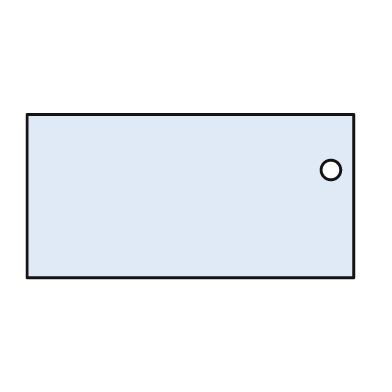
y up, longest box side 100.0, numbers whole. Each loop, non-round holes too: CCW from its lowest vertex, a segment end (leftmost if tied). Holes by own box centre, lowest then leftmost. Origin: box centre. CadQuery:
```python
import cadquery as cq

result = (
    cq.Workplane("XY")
    .moveTo(-50.0, -25.0)
    .lineTo(50.0, -25.0)
    .lineTo(50.0, 25.0)
    .lineTo(-50.0, 25.0)
    .close()
    .moveTo(43.0, 8.0)
    .circle(3.0)
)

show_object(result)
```